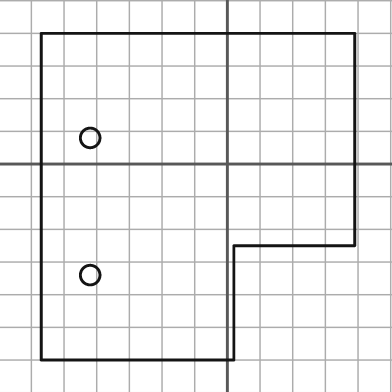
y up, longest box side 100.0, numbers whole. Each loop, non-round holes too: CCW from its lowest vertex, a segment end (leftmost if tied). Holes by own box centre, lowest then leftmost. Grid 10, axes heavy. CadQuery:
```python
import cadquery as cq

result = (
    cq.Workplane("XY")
    .moveTo(-57.0, -60.0)
    .lineTo(2.0, -60.0)
    .lineTo(2.0, -25.0)
    .lineTo(39.0, -25.0)
    .lineTo(39.0, 40.0)
    .lineTo(-57.0, 40.0)
    .close()
    .moveTo(-42.0, -34.0)
    .circle(3.0)
    .moveTo(-42.0, 8.0)
    .circle(3.0)
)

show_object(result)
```